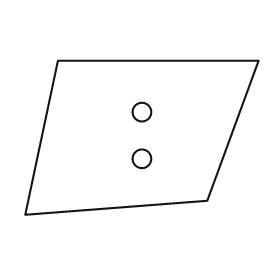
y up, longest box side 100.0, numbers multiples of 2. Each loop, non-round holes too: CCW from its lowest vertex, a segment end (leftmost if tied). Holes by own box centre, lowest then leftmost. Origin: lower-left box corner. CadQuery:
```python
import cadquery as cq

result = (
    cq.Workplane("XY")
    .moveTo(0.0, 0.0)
    .lineTo(78.0, 6.0)
    .lineTo(100.0, 66.0)
    .lineTo(14.0, 66.0)
    .close()
    .moveTo(50.0, 24.0)
    .circle(4.0)
    .moveTo(50.0, 44.0)
    .circle(4.0)
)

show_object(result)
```